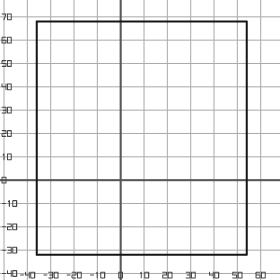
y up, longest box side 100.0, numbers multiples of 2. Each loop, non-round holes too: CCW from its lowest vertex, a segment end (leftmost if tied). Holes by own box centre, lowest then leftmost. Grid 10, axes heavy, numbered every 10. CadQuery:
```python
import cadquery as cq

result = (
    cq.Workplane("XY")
    .moveTo(-36.0, -32.0)
    .lineTo(54.0, -32.0)
    .lineTo(54.0, 68.0)
    .lineTo(-36.0, 68.0)
    .close()
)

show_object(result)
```